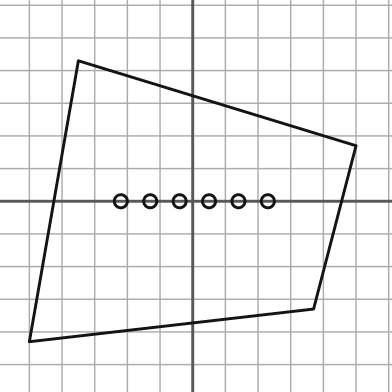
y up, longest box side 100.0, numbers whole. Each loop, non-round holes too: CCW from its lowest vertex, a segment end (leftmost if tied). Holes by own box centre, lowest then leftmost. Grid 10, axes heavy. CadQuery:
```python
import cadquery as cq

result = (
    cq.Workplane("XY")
    .moveTo(-50.0, -43.0)
    .lineTo(37.0, -33.0)
    .lineTo(50.0, 17.0)
    .lineTo(-35.0, 43.0)
    .close()
    .moveTo(-22.0, 0.0)
    .circle(2.0)
    .moveTo(-13.0, 0.0)
    .circle(2.0)
    .moveTo(-4.0, 0.0)
    .circle(2.0)
    .moveTo(5.0, 0.0)
    .circle(2.0)
    .moveTo(14.0, 0.0)
    .circle(2.0)
    .moveTo(23.0, 0.0)
    .circle(2.0)
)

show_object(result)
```